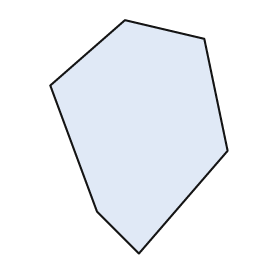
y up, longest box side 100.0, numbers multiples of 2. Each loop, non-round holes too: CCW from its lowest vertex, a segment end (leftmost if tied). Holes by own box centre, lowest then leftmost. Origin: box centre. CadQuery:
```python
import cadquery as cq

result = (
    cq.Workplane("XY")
    .moveTo(0.0, -50.0)
    .lineTo(38.0, -6.0)
    .lineTo(28.0, 42.0)
    .lineTo(-6.0, 50.0)
    .lineTo(-38.0, 22.0)
    .lineTo(-18.0, -32.0)
    .close()
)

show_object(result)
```